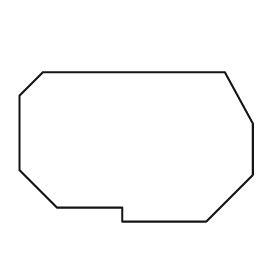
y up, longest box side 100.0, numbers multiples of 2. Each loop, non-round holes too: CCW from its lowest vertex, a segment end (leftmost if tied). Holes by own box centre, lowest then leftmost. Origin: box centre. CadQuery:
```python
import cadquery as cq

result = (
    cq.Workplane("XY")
    .moveTo(-6.0, -32.0)
    .lineTo(30.0, -32.0)
    .lineTo(50.0, -12.0)
    .lineTo(50.0, 10.0)
    .lineTo(38.0, 32.0)
    .lineTo(-40.0, 32.0)
    .lineTo(-50.0, 22.0)
    .lineTo(-50.0, -10.0)
    .lineTo(-34.0, -26.0)
    .lineTo(-6.0, -26.0)
    .close()
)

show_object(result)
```